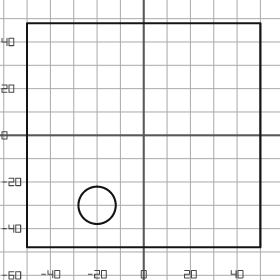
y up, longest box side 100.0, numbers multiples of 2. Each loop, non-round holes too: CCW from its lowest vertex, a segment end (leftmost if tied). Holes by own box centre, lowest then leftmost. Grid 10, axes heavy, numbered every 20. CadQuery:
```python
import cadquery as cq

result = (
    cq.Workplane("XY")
    .moveTo(-50.0, -48.0)
    .lineTo(50.0, -48.0)
    .lineTo(50.0, 48.0)
    .lineTo(-50.0, 48.0)
    .close()
    .moveTo(-20.0, -30.0)
    .circle(8.0)
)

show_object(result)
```